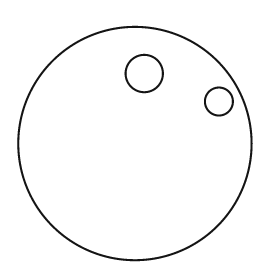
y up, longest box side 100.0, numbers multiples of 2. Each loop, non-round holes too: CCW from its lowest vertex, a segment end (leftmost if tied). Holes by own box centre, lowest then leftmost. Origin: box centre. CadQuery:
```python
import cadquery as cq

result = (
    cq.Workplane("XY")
    .moveTo(0.0, 0.0)
    .circle(50.0)
    .moveTo(36.0, 18.0)
    .circle(6.0)
    .moveTo(4.0, 30.0)
    .circle(8.0)
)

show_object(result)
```